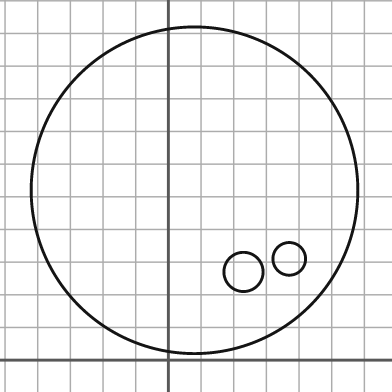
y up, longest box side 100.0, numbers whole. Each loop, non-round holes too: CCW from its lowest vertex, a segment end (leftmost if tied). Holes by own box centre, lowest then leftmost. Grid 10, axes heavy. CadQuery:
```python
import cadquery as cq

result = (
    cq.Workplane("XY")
    .moveTo(8.0, 52.0)
    .circle(50.0)
    .moveTo(23.0, 27.0)
    .circle(6.0)
    .moveTo(37.0, 31.0)
    .circle(5.0)
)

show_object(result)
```